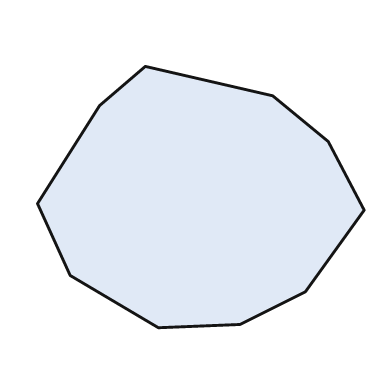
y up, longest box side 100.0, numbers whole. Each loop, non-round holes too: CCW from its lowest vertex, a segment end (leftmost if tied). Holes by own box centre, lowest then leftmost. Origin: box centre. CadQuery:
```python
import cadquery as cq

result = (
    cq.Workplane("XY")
    .moveTo(-13.0, -40.0)
    .lineTo(12.0, -39.0)
    .lineTo(32.0, -29.0)
    .lineTo(50.0, -4.0)
    .lineTo(39.0, 17.0)
    .lineTo(22.0, 31.0)
    .lineTo(-17.0, 40.0)
    .lineTo(-31.0, 28.0)
    .lineTo(-50.0, -2.0)
    .lineTo(-40.0, -24.0)
    .close()
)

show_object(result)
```